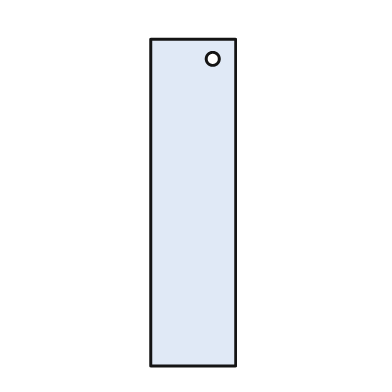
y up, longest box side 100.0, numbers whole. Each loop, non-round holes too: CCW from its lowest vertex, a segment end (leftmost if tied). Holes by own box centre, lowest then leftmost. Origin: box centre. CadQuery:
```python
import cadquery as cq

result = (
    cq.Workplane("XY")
    .moveTo(-13.0, -50.0)
    .lineTo(13.0, -50.0)
    .lineTo(13.0, 50.0)
    .lineTo(-13.0, 50.0)
    .close()
    .moveTo(6.0, 44.0)
    .circle(2.0)
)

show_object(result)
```